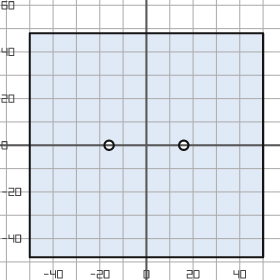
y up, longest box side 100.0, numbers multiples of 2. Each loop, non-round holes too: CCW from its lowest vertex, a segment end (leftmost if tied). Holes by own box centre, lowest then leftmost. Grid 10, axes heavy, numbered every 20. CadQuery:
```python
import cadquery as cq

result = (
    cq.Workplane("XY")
    .moveTo(-50.0, -48.0)
    .lineTo(50.0, -48.0)
    .lineTo(50.0, 48.0)
    .lineTo(-50.0, 48.0)
    .close()
    .moveTo(-16.0, 0.0)
    .circle(2.0)
    .moveTo(16.0, 0.0)
    .circle(2.0)
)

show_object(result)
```